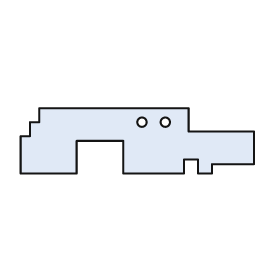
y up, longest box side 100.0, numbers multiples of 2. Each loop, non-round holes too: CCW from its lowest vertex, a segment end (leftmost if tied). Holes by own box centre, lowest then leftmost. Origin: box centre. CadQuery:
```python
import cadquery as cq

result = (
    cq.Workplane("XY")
    .moveTo(-50.0, -14.0)
    .lineTo(-26.0, -14.0)
    .lineTo(-26.0, 0.0)
    .lineTo(-6.0, 0.0)
    .lineTo(-6.0, -14.0)
    .lineTo(20.0, -14.0)
    .lineTo(20.0, -8.0)
    .lineTo(26.0, -8.0)
    .lineTo(26.0, -14.0)
    .lineTo(32.0, -14.0)
    .lineTo(32.0, -10.0)
    .lineTo(50.0, -10.0)
    .lineTo(50.0, 4.0)
    .lineTo(22.0, 4.0)
    .lineTo(22.0, 14.0)
    .lineTo(-42.0, 14.0)
    .lineTo(-42.0, 8.0)
    .lineTo(-46.0, 8.0)
    .lineTo(-46.0, 2.0)
    .lineTo(-50.0, 2.0)
    .close()
    .moveTo(2.0, 8.0)
    .circle(2.0)
    .moveTo(12.0, 8.0)
    .circle(2.0)
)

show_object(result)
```